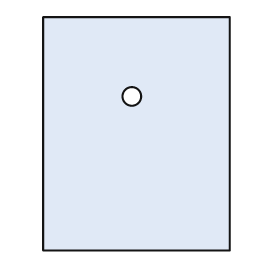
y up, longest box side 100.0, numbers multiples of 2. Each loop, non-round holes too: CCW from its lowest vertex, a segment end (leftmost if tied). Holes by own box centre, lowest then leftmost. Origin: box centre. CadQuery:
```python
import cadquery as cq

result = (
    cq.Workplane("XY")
    .moveTo(-40.0, -50.0)
    .lineTo(40.0, -50.0)
    .lineTo(40.0, 50.0)
    .lineTo(-40.0, 50.0)
    .close()
    .moveTo(-2.0, 16.0)
    .circle(4.0)
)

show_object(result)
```